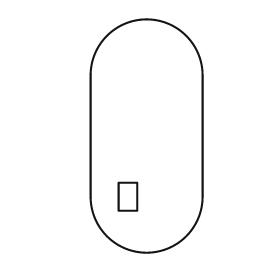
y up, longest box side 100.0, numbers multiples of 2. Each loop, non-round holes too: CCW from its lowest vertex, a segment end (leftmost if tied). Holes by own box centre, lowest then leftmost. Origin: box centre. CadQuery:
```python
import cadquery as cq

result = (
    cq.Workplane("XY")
    .moveTo(-24.0, -26.0)
    .threePointArc((0.0, -50.0), (24.0, -26.0))
    .lineTo(24.0, 26.0)
    .threePointArc((0.0, 50.0), (-24.0, 26.0))
    .close()
    .moveTo(-12.0, -32.0)
    .lineTo(-4.0, -32.0)
    .lineTo(-4.0, -20.0)
    .lineTo(-12.0, -20.0)
    .close()
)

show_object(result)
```